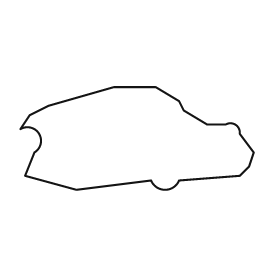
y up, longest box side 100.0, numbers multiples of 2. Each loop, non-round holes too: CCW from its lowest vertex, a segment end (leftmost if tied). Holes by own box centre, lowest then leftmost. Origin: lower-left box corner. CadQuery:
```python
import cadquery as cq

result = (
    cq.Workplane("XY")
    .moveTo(24.0, 0.0)
    .lineTo(56.0, 4.0)
    .threePointArc((62.0, 0.0), (68.0, 4.0))
    .lineTo(94.0, 6.0)
    .lineTo(98.0, 10.0)
    .lineTo(100.0, 16.0)
    .lineTo(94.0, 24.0)
    .threePointArc((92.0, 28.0), (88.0, 28.0))
    .lineTo(80.0, 28.0)
    .lineTo(70.0, 34.0)
    .lineTo(68.0, 38.0)
    .lineTo(58.0, 44.0)
    .lineTo(40.0, 44.0)
    .lineTo(12.0, 36.0)
    .lineTo(4.0, 32.0)
    .lineTo(0.0, 26.0)
    .threePointArc((8.0, 24.0), (6.0, 16.0))
    .lineTo(2.0, 6.0)
    .close()
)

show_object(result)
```